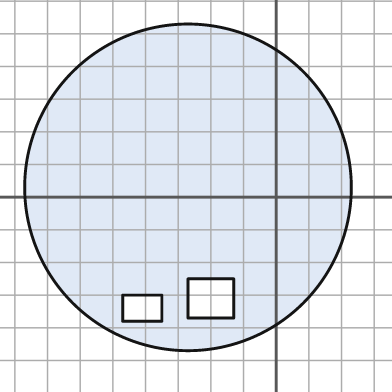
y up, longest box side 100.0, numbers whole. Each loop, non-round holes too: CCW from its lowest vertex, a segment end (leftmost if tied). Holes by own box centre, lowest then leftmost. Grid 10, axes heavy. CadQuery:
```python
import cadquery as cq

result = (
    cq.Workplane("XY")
    .moveTo(-27.0, 3.0)
    .circle(50.0)
    .moveTo(-47.0, -38.0)
    .lineTo(-35.0, -38.0)
    .lineTo(-35.0, -30.0)
    .lineTo(-47.0, -30.0)
    .close()
    .moveTo(-27.0, -37.0)
    .lineTo(-13.0, -37.0)
    .lineTo(-13.0, -25.0)
    .lineTo(-27.0, -25.0)
    .close()
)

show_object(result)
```